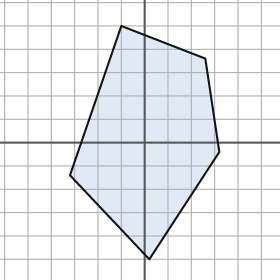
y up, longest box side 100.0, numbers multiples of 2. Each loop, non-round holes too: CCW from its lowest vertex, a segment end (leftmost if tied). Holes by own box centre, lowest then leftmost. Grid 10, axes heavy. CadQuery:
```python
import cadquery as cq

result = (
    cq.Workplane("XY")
    .moveTo(2.0, -50.0)
    .lineTo(32.0, -4.0)
    .lineTo(26.0, 36.0)
    .lineTo(-10.0, 50.0)
    .lineTo(-32.0, -14.0)
    .close()
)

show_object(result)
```